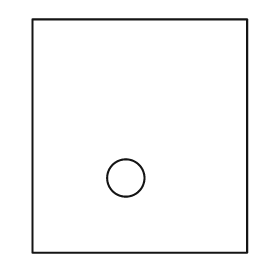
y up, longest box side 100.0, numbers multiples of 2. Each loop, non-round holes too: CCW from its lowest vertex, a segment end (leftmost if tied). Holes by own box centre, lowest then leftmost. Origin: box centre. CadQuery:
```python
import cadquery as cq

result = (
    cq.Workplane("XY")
    .moveTo(-46.0, -50.0)
    .lineTo(46.0, -50.0)
    .lineTo(46.0, 50.0)
    .lineTo(-46.0, 50.0)
    .close()
    .moveTo(-6.0, -18.0)
    .circle(8.0)
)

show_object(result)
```